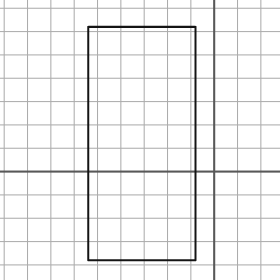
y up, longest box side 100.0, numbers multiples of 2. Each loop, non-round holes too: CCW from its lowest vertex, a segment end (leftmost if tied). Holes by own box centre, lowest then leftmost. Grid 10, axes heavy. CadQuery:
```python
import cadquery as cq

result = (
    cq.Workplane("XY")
    .moveTo(-54.0, -38.0)
    .lineTo(-8.0, -38.0)
    .lineTo(-8.0, 62.0)
    .lineTo(-54.0, 62.0)
    .close()
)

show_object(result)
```